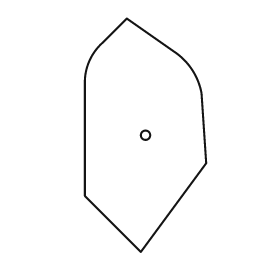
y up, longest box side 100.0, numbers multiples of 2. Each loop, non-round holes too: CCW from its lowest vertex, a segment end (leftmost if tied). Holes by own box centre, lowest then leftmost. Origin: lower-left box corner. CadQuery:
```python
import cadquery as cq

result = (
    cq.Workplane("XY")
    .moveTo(24.0, 0.0)
    .lineTo(52.0, 38.0)
    .lineTo(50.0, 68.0)
    .threePointArc((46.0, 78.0), (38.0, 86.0))
    .lineTo(18.0, 100.0)
    .lineTo(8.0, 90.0)
    .threePointArc((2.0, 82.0), (0.0, 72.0))
    .lineTo(0.0, 24.0)
    .close()
    .moveTo(26.0, 50.0)
    .circle(2.0)
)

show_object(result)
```